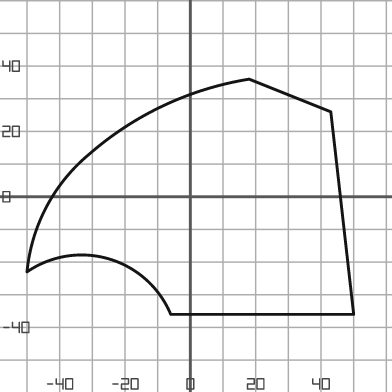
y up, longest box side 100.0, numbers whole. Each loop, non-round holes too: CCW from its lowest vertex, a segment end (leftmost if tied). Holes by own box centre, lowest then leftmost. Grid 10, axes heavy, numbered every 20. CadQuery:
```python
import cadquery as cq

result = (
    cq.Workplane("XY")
    .moveTo(-6.0, -36.0)
    .lineTo(50.0, -36.0)
    .lineTo(43.0, 26.0)
    .lineTo(18.0, 36.0)
    .threePointArc((-8.0, 28.0), (-31.0, 13.0))
    .threePointArc((-44.0, -3.0), (-50.0, -23.0))
    .threePointArc((-25.0, -19.0), (-6.0, -36.0))
    .close()
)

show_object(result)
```